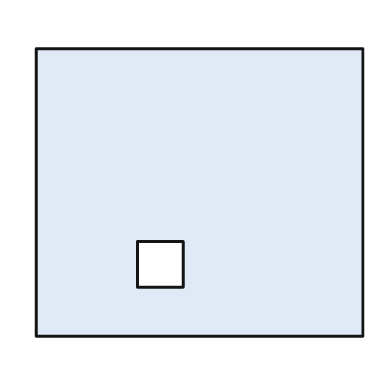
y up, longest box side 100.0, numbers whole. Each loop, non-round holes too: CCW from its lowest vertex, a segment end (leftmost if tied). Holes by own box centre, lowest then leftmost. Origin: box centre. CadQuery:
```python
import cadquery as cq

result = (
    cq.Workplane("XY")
    .moveTo(-50.0, -44.0)
    .lineTo(50.0, -44.0)
    .lineTo(50.0, 44.0)
    .lineTo(-50.0, 44.0)
    .close()
    .moveTo(-19.0, -29.0)
    .lineTo(-5.0, -29.0)
    .lineTo(-5.0, -15.0)
    .lineTo(-19.0, -15.0)
    .close()
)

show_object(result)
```